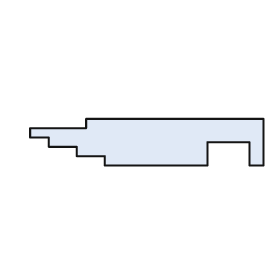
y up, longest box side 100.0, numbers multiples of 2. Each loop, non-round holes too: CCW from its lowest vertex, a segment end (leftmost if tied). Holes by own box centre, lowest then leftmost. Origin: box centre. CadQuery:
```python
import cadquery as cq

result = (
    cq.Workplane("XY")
    .moveTo(-18.0, -10.0)
    .lineTo(26.0, -10.0)
    .lineTo(26.0, 0.0)
    .lineTo(44.0, 0.0)
    .lineTo(44.0, -10.0)
    .lineTo(50.0, -10.0)
    .lineTo(50.0, 10.0)
    .lineTo(-26.0, 10.0)
    .lineTo(-26.0, 6.0)
    .lineTo(-50.0, 6.0)
    .lineTo(-50.0, 2.0)
    .lineTo(-42.0, 2.0)
    .lineTo(-42.0, -2.0)
    .lineTo(-30.0, -2.0)
    .lineTo(-30.0, -6.0)
    .lineTo(-18.0, -6.0)
    .close()
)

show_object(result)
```